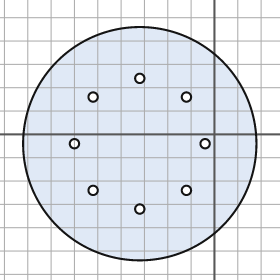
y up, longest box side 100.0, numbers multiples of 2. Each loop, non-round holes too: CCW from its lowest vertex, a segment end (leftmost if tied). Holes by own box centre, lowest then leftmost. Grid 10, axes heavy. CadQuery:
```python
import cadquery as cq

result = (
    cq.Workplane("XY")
    .moveTo(-32.0, -4.0)
    .circle(50.0)
    .moveTo(-32.0, -32.0)
    .circle(2.0)
    .moveTo(-52.0, -24.0)
    .circle(2.0)
    .moveTo(-12.0, -24.0)
    .circle(2.0)
    .moveTo(-60.0, -4.0)
    .circle(2.0)
    .moveTo(-4.0, -4.0)
    .circle(2.0)
    .moveTo(-52.0, 16.0)
    .circle(2.0)
    .moveTo(-12.0, 16.0)
    .circle(2.0)
    .moveTo(-32.0, 24.0)
    .circle(2.0)
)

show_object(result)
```